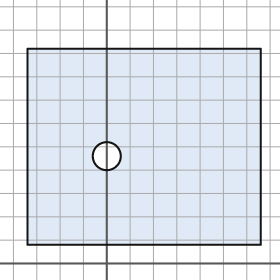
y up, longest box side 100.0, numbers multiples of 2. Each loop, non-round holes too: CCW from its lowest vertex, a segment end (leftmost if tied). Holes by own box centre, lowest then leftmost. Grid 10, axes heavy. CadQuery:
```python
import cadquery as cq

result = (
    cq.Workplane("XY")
    .moveTo(-34.0, 8.0)
    .lineTo(66.0, 8.0)
    .lineTo(66.0, 92.0)
    .lineTo(-34.0, 92.0)
    .close()
    .moveTo(0.0, 46.0)
    .circle(6.0)
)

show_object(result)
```